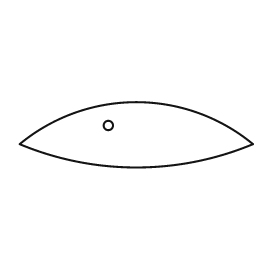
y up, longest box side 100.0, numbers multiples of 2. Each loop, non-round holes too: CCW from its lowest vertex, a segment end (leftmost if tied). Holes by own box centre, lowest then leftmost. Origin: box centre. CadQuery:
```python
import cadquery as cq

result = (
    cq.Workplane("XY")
    .moveTo(-50.0, -4.0)
    .threePointArc((0.0, -14.0), (50.0, -4.0))
    .threePointArc((0.0, 14.0), (-50.0, -4.0))
    .close()
    .moveTo(-12.0, 4.0)
    .circle(2.0)
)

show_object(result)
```